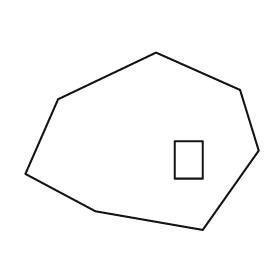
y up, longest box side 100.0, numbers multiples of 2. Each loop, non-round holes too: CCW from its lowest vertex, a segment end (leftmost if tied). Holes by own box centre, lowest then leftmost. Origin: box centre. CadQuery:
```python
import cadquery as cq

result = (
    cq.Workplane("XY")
    .moveTo(26.0, -38.0)
    .lineTo(50.0, -4.0)
    .lineTo(42.0, 22.0)
    .lineTo(6.0, 38.0)
    .lineTo(-36.0, 18.0)
    .lineTo(-50.0, -14.0)
    .lineTo(-20.0, -30.0)
    .close()
    .moveTo(14.0, -16.0)
    .lineTo(26.0, -16.0)
    .lineTo(26.0, 0.0)
    .lineTo(14.0, 0.0)
    .close()
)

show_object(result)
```